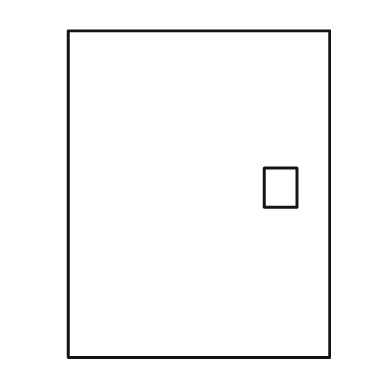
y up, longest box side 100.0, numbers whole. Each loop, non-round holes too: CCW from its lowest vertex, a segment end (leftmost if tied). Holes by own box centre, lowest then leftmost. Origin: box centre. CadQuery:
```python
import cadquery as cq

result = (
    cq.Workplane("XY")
    .moveTo(-40.0, -50.0)
    .lineTo(40.0, -50.0)
    .lineTo(40.0, 50.0)
    .lineTo(-40.0, 50.0)
    .close()
    .moveTo(20.0, -4.0)
    .lineTo(30.0, -4.0)
    .lineTo(30.0, 8.0)
    .lineTo(20.0, 8.0)
    .close()
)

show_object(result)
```